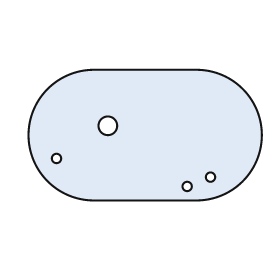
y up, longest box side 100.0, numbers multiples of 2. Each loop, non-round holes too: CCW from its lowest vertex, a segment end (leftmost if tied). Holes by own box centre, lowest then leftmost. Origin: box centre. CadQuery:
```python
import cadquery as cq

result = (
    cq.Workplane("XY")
    .moveTo(-22.0, -28.0)
    .lineTo(22.0, -28.0)
    .threePointArc((50.0, 0.0), (22.0, 28.0))
    .lineTo(-22.0, 28.0)
    .threePointArc((-50.0, 0.0), (-22.0, -28.0))
    .close()
    .moveTo(18.0, -22.0)
    .circle(2.0)
    .moveTo(28.0, -18.0)
    .circle(2.0)
    .moveTo(-38.0, -10.0)
    .circle(2.0)
    .moveTo(-16.0, 4.0)
    .circle(4.0)
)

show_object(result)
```